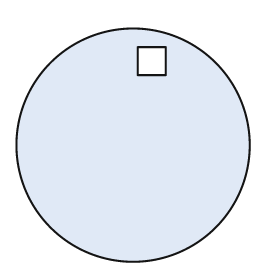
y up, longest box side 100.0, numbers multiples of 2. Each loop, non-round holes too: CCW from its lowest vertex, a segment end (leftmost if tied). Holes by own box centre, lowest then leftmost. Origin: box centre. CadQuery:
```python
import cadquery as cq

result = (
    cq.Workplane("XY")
    .moveTo(0.0, 0.0)
    .circle(50.0)
    .moveTo(2.0, 30.0)
    .lineTo(14.0, 30.0)
    .lineTo(14.0, 42.0)
    .lineTo(2.0, 42.0)
    .close()
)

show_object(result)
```